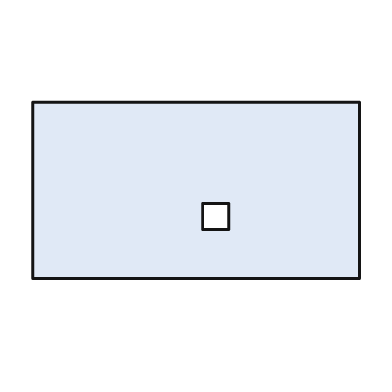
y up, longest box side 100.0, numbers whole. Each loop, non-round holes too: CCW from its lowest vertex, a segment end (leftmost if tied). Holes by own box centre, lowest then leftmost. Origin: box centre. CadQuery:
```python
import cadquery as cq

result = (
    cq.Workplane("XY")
    .moveTo(-50.0, -27.0)
    .lineTo(50.0, -27.0)
    .lineTo(50.0, 27.0)
    .lineTo(-50.0, 27.0)
    .close()
    .moveTo(2.0, -12.0)
    .lineTo(10.0, -12.0)
    .lineTo(10.0, -4.0)
    .lineTo(2.0, -4.0)
    .close()
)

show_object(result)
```